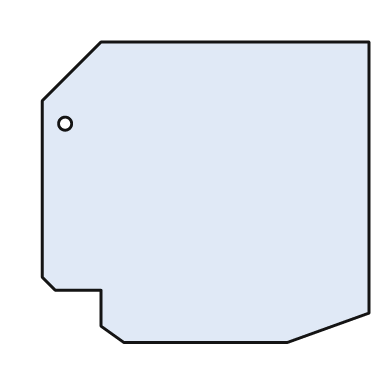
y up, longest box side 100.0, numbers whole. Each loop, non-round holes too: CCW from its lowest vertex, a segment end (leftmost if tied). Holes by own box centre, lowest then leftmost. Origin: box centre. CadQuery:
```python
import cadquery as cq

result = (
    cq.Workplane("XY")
    .moveTo(-25.0, -46.0)
    .lineTo(25.0, -46.0)
    .lineTo(50.0, -37.0)
    .lineTo(50.0, 46.0)
    .lineTo(-32.0, 46.0)
    .lineTo(-50.0, 28.0)
    .lineTo(-50.0, -26.0)
    .lineTo(-46.0, -30.0)
    .lineTo(-32.0, -30.0)
    .lineTo(-32.0, -41.0)
    .close()
    .moveTo(-43.0, 21.0)
    .circle(2.0)
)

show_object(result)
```